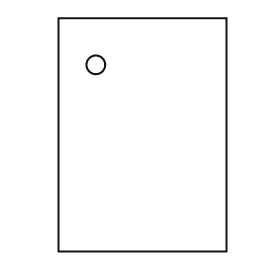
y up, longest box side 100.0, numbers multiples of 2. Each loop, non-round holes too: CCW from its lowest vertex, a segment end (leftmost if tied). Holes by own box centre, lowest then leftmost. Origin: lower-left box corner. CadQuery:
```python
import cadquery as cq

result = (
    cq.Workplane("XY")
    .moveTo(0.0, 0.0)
    .lineTo(72.0, 0.0)
    .lineTo(72.0, 100.0)
    .lineTo(0.0, 100.0)
    .close()
    .moveTo(16.0, 80.0)
    .circle(4.0)
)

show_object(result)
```